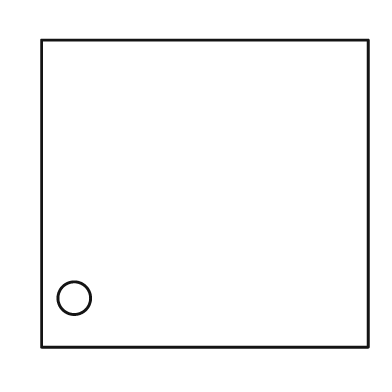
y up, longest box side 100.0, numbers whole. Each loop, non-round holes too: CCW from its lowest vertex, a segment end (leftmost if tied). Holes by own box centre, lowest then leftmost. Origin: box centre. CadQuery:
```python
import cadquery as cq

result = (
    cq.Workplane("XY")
    .moveTo(-50.0, -47.0)
    .lineTo(50.0, -47.0)
    .lineTo(50.0, 47.0)
    .lineTo(-50.0, 47.0)
    .close()
    .moveTo(-40.0, -32.0)
    .circle(5.0)
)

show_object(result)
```